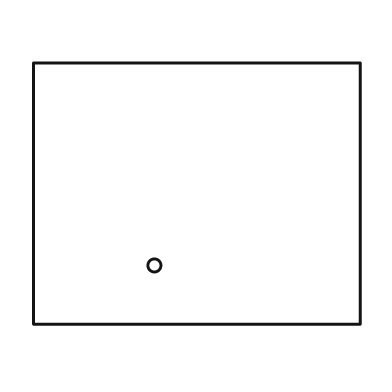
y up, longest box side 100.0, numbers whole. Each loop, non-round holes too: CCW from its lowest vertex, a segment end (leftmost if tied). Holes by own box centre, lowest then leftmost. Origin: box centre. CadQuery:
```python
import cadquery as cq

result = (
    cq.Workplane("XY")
    .moveTo(-50.0, -40.0)
    .lineTo(50.0, -40.0)
    .lineTo(50.0, 40.0)
    .lineTo(-50.0, 40.0)
    .close()
    .moveTo(-13.0, -22.0)
    .circle(2.0)
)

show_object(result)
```